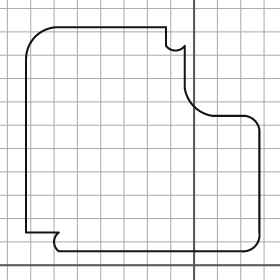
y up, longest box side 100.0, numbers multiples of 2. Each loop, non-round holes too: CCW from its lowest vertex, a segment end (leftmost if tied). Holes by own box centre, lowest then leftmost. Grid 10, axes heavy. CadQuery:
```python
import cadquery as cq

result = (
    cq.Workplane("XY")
    .moveTo(-58.0, 6.0)
    .lineTo(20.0, 6.0)
    .threePointArc((26.0, 8.0), (28.0, 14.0))
    .lineTo(28.0, 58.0)
    .threePointArc((26.0, 62.0), (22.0, 64.0))
    .lineTo(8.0, 64.0)
    .threePointArc((0.0, 68.0), (-4.0, 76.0))
    .lineTo(-4.0, 94.0)
    .threePointArc((-8.0, 92.0), (-12.0, 94.0))
    .lineTo(-12.0, 102.0)
    .lineTo(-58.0, 102.0)
    .threePointArc((-68.0, 98.0), (-72.0, 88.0))
    .lineTo(-72.0, 14.0)
    .lineTo(-58.0, 14.0)
    .threePointArc((-60.0, 10.0), (-58.0, 6.0))
    .close()
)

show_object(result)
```